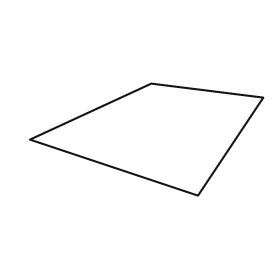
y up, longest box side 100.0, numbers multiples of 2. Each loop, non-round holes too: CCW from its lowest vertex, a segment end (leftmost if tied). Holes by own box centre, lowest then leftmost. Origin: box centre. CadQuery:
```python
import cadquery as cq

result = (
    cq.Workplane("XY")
    .moveTo(22.0, -24.0)
    .lineTo(50.0, 18.0)
    .lineTo(2.0, 24.0)
    .lineTo(-50.0, 0.0)
    .close()
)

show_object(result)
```